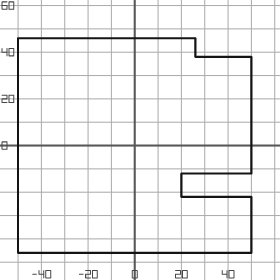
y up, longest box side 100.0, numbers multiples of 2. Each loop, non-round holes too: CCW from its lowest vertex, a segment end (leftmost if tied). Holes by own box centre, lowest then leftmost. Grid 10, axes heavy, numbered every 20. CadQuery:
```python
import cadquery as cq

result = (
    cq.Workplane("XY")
    .moveTo(-50.0, -46.0)
    .lineTo(50.0, -46.0)
    .lineTo(50.0, -22.0)
    .lineTo(20.0, -22.0)
    .lineTo(20.0, -12.0)
    .lineTo(50.0, -12.0)
    .lineTo(50.0, 38.0)
    .lineTo(26.0, 38.0)
    .lineTo(26.0, 46.0)
    .lineTo(-50.0, 46.0)
    .close()
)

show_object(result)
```